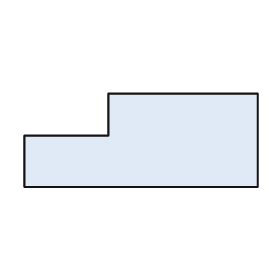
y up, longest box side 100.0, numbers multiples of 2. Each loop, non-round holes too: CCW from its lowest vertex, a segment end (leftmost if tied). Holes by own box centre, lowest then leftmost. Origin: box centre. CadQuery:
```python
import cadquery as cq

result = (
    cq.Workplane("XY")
    .moveTo(-50.0, -20.0)
    .lineTo(50.0, -20.0)
    .lineTo(50.0, 20.0)
    .lineTo(-14.0, 20.0)
    .lineTo(-14.0, 2.0)
    .lineTo(-50.0, 2.0)
    .close()
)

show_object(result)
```